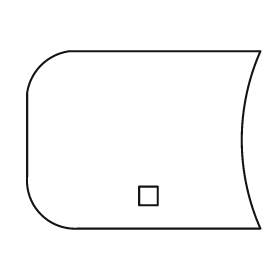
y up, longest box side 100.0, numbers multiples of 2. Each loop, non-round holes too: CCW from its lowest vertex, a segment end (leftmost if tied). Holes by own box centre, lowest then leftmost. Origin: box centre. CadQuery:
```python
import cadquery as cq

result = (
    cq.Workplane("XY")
    .moveTo(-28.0, -38.0)
    .lineTo(50.0, -38.0)
    .threePointArc((42.0, 0.0), (50.0, 38.0))
    .lineTo(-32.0, 38.0)
    .threePointArc((-44.0, 32.0), (-50.0, 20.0))
    .lineTo(-50.0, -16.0)
    .threePointArc((-44.0, -32.0), (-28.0, -38.0))
    .close()
    .moveTo(-2.0, -28.0)
    .lineTo(6.0, -28.0)
    .lineTo(6.0, -20.0)
    .lineTo(-2.0, -20.0)
    .close()
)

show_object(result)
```